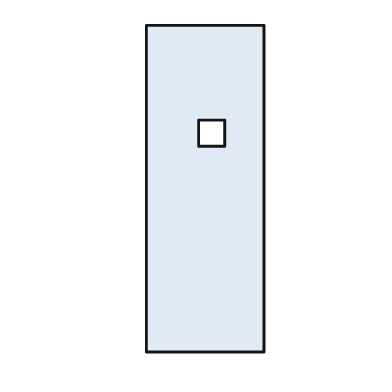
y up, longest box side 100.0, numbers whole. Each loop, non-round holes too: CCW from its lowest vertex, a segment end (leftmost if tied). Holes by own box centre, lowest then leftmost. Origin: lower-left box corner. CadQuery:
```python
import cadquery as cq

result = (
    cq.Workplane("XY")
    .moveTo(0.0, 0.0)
    .lineTo(36.0, 0.0)
    .lineTo(36.0, 100.0)
    .lineTo(0.0, 100.0)
    .close()
    .moveTo(16.0, 63.0)
    .lineTo(24.0, 63.0)
    .lineTo(24.0, 71.0)
    .lineTo(16.0, 71.0)
    .close()
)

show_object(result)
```